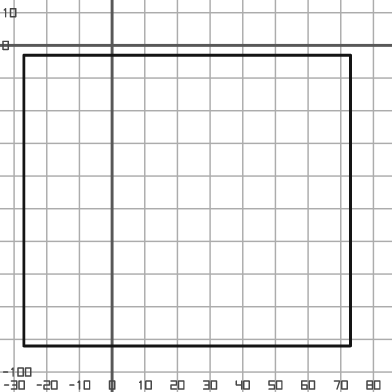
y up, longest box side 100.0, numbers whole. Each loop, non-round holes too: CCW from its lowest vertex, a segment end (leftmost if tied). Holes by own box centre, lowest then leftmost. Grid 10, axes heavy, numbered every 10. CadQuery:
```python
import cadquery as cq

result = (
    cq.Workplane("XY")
    .moveTo(-27.0, -92.0)
    .lineTo(73.0, -92.0)
    .lineTo(73.0, -3.0)
    .lineTo(-27.0, -3.0)
    .close()
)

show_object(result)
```